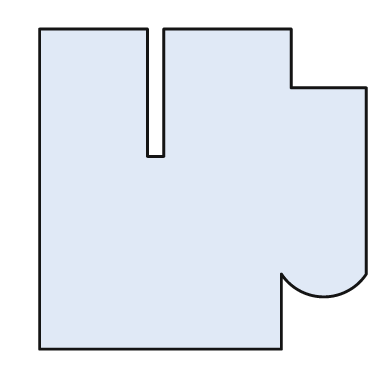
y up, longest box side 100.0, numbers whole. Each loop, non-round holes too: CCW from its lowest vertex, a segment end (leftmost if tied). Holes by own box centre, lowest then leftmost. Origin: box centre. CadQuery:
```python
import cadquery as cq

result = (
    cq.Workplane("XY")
    .moveTo(-50.0, -49.0)
    .lineTo(24.0, -49.0)
    .lineTo(24.0, -26.0)
    .threePointArc((37.0, -33.0), (50.0, -26.0))
    .lineTo(50.0, 31.0)
    .lineTo(27.0, 31.0)
    .lineTo(27.0, 49.0)
    .lineTo(-12.0, 49.0)
    .lineTo(-12.0, 10.0)
    .lineTo(-17.0, 10.0)
    .lineTo(-17.0, 49.0)
    .lineTo(-50.0, 49.0)
    .close()
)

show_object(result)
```